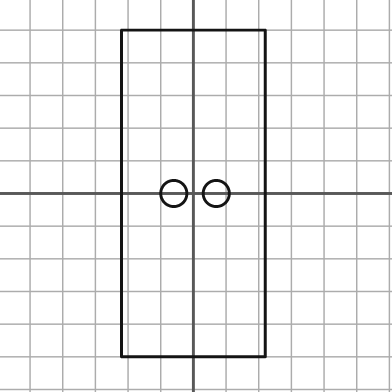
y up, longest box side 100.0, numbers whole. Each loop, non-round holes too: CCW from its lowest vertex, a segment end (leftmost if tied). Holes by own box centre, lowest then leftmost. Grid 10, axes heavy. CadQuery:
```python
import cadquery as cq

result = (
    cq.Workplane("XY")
    .moveTo(-22.0, -50.0)
    .lineTo(22.0, -50.0)
    .lineTo(22.0, 50.0)
    .lineTo(-22.0, 50.0)
    .close()
    .moveTo(-6.0, 0.0)
    .circle(4.0)
    .moveTo(7.0, 0.0)
    .circle(4.0)
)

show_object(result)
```